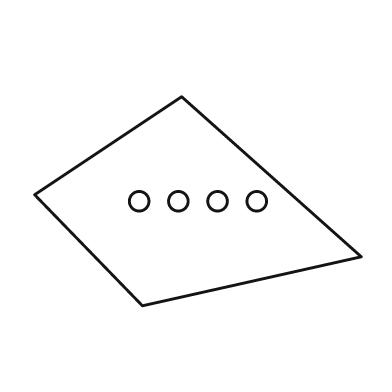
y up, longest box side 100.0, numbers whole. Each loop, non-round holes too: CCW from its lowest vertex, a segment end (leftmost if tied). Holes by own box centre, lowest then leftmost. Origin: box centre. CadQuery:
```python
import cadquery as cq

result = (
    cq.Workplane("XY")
    .moveTo(-17.0, -32.0)
    .lineTo(50.0, -17.0)
    .lineTo(-5.0, 32.0)
    .lineTo(-50.0, 2.0)
    .close()
    .moveTo(-18.0, 0.0)
    .circle(3.0)
    .moveTo(-6.0, 0.0)
    .circle(3.0)
    .moveTo(6.0, 0.0)
    .circle(3.0)
    .moveTo(18.0, 0.0)
    .circle(3.0)
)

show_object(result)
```